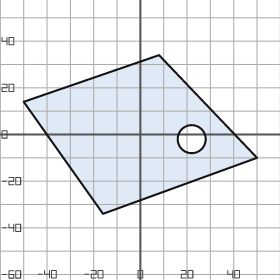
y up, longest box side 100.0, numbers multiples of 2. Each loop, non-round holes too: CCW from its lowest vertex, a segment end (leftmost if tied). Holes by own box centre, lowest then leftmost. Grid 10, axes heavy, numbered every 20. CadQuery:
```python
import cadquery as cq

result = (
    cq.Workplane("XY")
    .moveTo(-16.0, -34.0)
    .lineTo(50.0, -10.0)
    .lineTo(8.0, 34.0)
    .lineTo(-50.0, 14.0)
    .close()
    .moveTo(22.0, -2.0)
    .circle(6.0)
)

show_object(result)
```